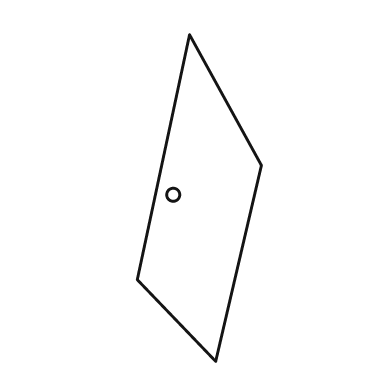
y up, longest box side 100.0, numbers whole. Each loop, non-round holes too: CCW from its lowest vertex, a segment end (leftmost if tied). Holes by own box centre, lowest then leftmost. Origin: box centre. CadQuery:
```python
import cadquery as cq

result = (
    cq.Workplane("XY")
    .moveTo(5.0, -50.0)
    .lineTo(19.0, 10.0)
    .lineTo(-3.0, 50.0)
    .lineTo(-19.0, -25.0)
    .close()
    .moveTo(-8.0, 1.0)
    .circle(2.0)
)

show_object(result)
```